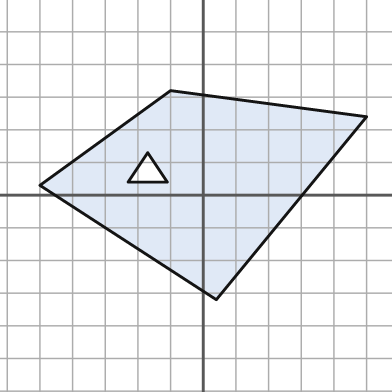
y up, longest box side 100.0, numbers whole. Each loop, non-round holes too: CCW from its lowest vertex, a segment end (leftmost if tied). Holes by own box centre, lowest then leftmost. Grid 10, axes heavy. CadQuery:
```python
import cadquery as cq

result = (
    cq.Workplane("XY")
    .moveTo(4.0, -32.0)
    .lineTo(50.0, 24.0)
    .lineTo(-10.0, 32.0)
    .lineTo(-50.0, 3.0)
    .close()
    .moveTo(-23.0, 4.0)
    .lineTo(-11.0, 4.0)
    .lineTo(-17.0, 13.0)
    .close()
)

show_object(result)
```